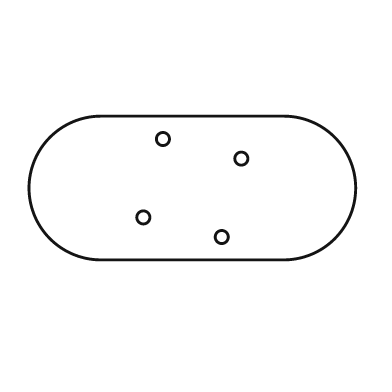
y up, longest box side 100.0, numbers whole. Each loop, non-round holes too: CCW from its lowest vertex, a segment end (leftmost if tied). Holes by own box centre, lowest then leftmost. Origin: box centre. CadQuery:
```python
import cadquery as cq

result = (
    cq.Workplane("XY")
    .moveTo(-28.0, -22.0)
    .lineTo(28.0, -22.0)
    .threePointArc((50.0, 0.0), (28.0, 22.0))
    .lineTo(-28.0, 22.0)
    .threePointArc((-50.0, 0.0), (-28.0, -22.0))
    .close()
    .moveTo(9.0, -15.0)
    .circle(2.0)
    .moveTo(-15.0, -9.0)
    .circle(2.0)
    .moveTo(15.0, 9.0)
    .circle(2.0)
    .moveTo(-9.0, 15.0)
    .circle(2.0)
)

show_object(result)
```